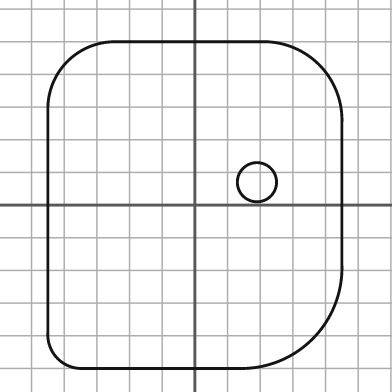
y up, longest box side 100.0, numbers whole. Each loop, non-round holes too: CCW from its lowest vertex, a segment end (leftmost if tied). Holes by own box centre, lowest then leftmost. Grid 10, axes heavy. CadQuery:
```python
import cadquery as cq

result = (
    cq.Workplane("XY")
    .moveTo(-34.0, -50.0)
    .lineTo(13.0, -50.0)
    .threePointArc((36.0, -41.0), (45.0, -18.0))
    .lineTo(45.0, 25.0)
    .threePointArc((38.0, 43.0), (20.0, 50.0))
    .lineTo(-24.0, 50.0)
    .threePointArc((-39.0, 44.0), (-45.0, 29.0))
    .lineTo(-45.0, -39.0)
    .threePointArc((-42.0, -47.0), (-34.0, -50.0))
    .close()
    .moveTo(19.0, 7.0)
    .circle(6.0)
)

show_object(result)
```